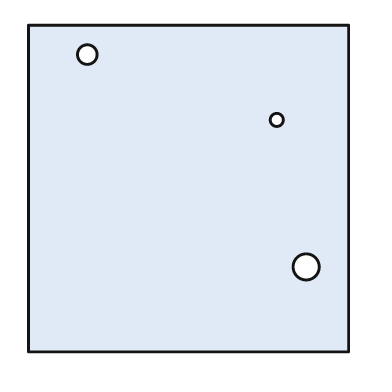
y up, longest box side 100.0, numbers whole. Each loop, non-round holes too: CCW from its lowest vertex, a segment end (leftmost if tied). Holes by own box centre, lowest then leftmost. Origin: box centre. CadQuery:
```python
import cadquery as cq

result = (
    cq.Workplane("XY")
    .moveTo(-49.0, -50.0)
    .lineTo(49.0, -50.0)
    .lineTo(49.0, 50.0)
    .lineTo(-49.0, 50.0)
    .close()
    .moveTo(36.0, -24.0)
    .circle(4.0)
    .moveTo(27.0, 21.0)
    .circle(2.0)
    .moveTo(-31.0, 41.0)
    .circle(3.0)
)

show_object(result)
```